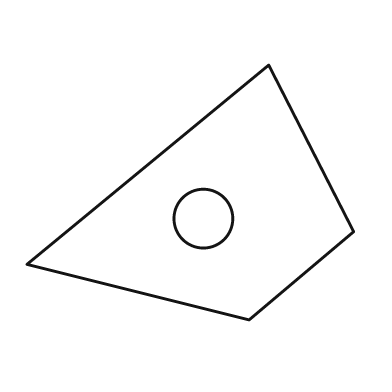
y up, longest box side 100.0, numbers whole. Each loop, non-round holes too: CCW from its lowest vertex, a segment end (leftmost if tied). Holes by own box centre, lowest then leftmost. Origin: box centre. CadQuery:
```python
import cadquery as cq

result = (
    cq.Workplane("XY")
    .moveTo(18.0, -39.0)
    .lineTo(50.0, -12.0)
    .lineTo(24.0, 39.0)
    .lineTo(-50.0, -22.0)
    .close()
    .moveTo(4.0, -8.0)
    .circle(9.0)
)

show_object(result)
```